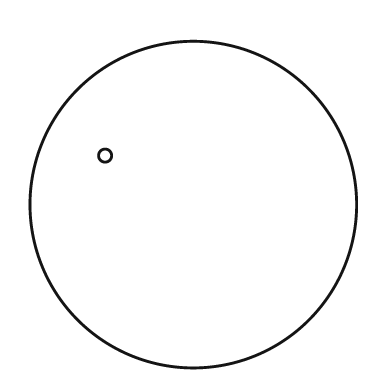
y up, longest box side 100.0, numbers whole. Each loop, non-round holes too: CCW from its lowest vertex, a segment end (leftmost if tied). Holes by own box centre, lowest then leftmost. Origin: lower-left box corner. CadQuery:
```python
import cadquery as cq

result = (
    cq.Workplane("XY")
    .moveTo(50.0, 50.0)
    .circle(50.0)
    .moveTo(23.0, 65.0)
    .circle(2.0)
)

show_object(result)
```